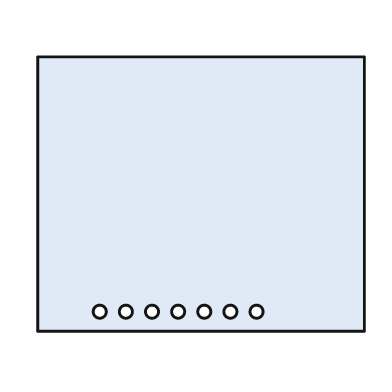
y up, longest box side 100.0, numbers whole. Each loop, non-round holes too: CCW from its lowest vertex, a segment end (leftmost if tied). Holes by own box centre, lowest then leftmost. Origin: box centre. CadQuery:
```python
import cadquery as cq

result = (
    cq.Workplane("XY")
    .moveTo(-50.0, -42.0)
    .lineTo(50.0, -42.0)
    .lineTo(50.0, 42.0)
    .lineTo(-50.0, 42.0)
    .close()
    .moveTo(-31.0, -36.0)
    .circle(2.0)
    .moveTo(-23.0, -36.0)
    .circle(2.0)
    .moveTo(-15.0, -36.0)
    .circle(2.0)
    .moveTo(-7.0, -36.0)
    .circle(2.0)
    .moveTo(1.0, -36.0)
    .circle(2.0)
    .moveTo(9.0, -36.0)
    .circle(2.0)
    .moveTo(17.0, -36.0)
    .circle(2.0)
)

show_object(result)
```